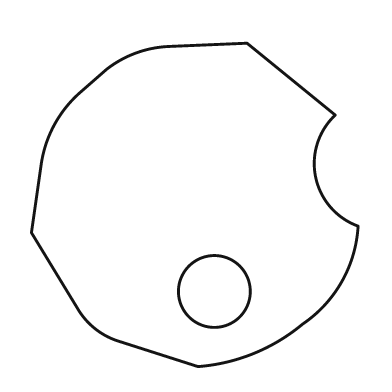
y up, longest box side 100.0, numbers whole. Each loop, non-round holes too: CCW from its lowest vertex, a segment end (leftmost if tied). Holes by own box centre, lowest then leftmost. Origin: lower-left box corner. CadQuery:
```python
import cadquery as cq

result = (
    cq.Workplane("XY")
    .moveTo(51.0, 0.0)
    .threePointArc((68.0, 4.0), (83.0, 13.0))
    .threePointArc((95.0, 26.0), (100.0, 43.0))
    .threePointArc((87.0, 58.0), (93.0, 77.0))
    .lineTo(66.0, 99.0)
    .lineTo(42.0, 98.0)
    .threePointArc((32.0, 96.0), (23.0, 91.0))
    .lineTo(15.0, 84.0)
    .threePointArc((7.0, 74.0), (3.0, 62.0))
    .lineTo(0.0, 41.0)
    .lineTo(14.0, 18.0)
    .threePointArc((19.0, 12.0), (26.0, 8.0))
    .close()
    .moveTo(56.0, 23.0)
    .circle(11.0)
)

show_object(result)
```